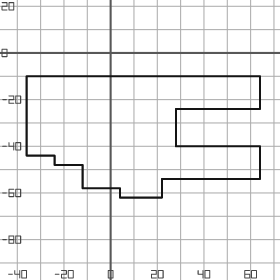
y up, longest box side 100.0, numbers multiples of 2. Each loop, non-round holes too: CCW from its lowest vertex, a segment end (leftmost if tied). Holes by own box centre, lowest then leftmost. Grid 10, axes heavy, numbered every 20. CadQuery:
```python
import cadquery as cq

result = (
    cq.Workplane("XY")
    .moveTo(4.0, -62.0)
    .lineTo(22.0, -62.0)
    .lineTo(22.0, -54.0)
    .lineTo(64.0, -54.0)
    .lineTo(64.0, -40.0)
    .lineTo(28.0, -40.0)
    .lineTo(28.0, -24.0)
    .lineTo(64.0, -24.0)
    .lineTo(64.0, -10.0)
    .lineTo(-36.0, -10.0)
    .lineTo(-36.0, -44.0)
    .lineTo(-24.0, -44.0)
    .lineTo(-24.0, -48.0)
    .lineTo(-12.0, -48.0)
    .lineTo(-12.0, -58.0)
    .lineTo(4.0, -58.0)
    .close()
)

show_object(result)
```